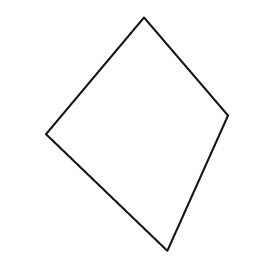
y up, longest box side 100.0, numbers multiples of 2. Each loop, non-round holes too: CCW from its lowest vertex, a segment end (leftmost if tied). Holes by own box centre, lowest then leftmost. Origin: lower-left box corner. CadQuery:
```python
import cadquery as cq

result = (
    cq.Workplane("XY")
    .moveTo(52.0, 0.0)
    .lineTo(78.0, 58.0)
    .lineTo(42.0, 100.0)
    .lineTo(0.0, 50.0)
    .close()
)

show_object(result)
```